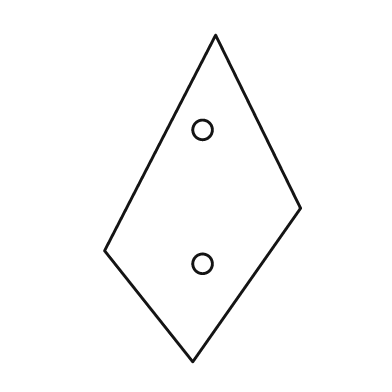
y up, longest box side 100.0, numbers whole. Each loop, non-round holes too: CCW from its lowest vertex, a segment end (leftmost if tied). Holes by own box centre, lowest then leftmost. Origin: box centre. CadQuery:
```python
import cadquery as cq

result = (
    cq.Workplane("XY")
    .moveTo(-3.0, -50.0)
    .lineTo(30.0, -3.0)
    .lineTo(4.0, 50.0)
    .lineTo(-30.0, -16.0)
    .close()
    .moveTo(0.0, -20.0)
    .circle(3.0)
    .moveTo(0.0, 21.0)
    .circle(3.0)
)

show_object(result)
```